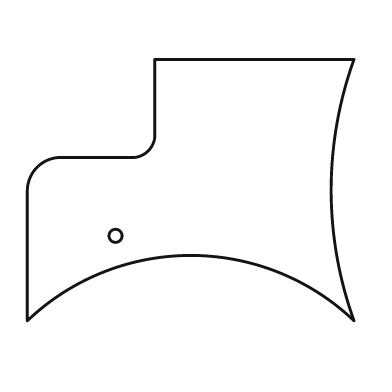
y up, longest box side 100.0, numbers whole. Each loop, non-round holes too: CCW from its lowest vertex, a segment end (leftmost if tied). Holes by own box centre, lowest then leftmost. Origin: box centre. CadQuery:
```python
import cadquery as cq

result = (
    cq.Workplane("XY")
    .moveTo(-50.0, -40.0)
    .threePointArc((0.0, -20.0), (50.0, -40.0))
    .threePointArc((43.0, 0.0), (50.0, 40.0))
    .lineTo(-11.0, 40.0)
    .lineTo(-11.0, 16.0)
    .threePointArc((-13.0, 12.0), (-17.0, 10.0))
    .lineTo(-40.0, 10.0)
    .threePointArc((-47.0, 7.0), (-50.0, 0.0))
    .close()
    .moveTo(-23.0, -14.0)
    .circle(2.0)
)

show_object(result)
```